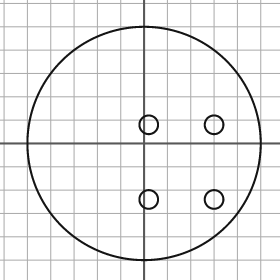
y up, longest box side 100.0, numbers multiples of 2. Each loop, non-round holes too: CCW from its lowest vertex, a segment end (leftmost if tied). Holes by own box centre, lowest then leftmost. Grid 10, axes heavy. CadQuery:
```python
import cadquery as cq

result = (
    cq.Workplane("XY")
    .moveTo(0.0, 0.0)
    .circle(50.0)
    .moveTo(2.0, -24.0)
    .circle(4.0)
    .moveTo(30.0, -24.0)
    .circle(4.0)
    .moveTo(2.0, 8.0)
    .circle(4.0)
    .moveTo(30.0, 8.0)
    .circle(4.0)
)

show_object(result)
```